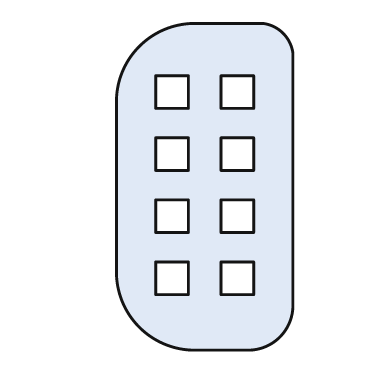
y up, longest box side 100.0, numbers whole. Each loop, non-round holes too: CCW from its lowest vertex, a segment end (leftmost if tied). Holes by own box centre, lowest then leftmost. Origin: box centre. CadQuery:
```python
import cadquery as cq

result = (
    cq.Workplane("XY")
    .moveTo(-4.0, -50.0)
    .lineTo(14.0, -50.0)
    .threePointArc((23.0, -46.0), (27.0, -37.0))
    .lineTo(27.0, 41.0)
    .threePointArc((24.0, 47.0), (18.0, 50.0))
    .lineTo(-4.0, 50.0)
    .threePointArc((-20.0, 43.0), (-27.0, 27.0))
    .lineTo(-27.0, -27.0)
    .threePointArc((-20.0, -43.0), (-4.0, -50.0))
    .close()
    .moveTo(-15.0, -33.0)
    .lineTo(-5.0, -33.0)
    .lineTo(-5.0, -23.0)
    .lineTo(-15.0, -23.0)
    .close()
    .moveTo(5.0, -33.0)
    .lineTo(15.0, -33.0)
    .lineTo(15.0, -23.0)
    .lineTo(5.0, -23.0)
    .close()
    .moveTo(-15.0, -14.0)
    .lineTo(-5.0, -14.0)
    .lineTo(-5.0, -4.0)
    .lineTo(-15.0, -4.0)
    .close()
    .moveTo(5.0, -14.0)
    .lineTo(15.0, -14.0)
    .lineTo(15.0, -4.0)
    .lineTo(5.0, -4.0)
    .close()
    .moveTo(-15.0, 5.0)
    .lineTo(-5.0, 5.0)
    .lineTo(-5.0, 15.0)
    .lineTo(-15.0, 15.0)
    .close()
    .moveTo(5.0, 5.0)
    .lineTo(15.0, 5.0)
    .lineTo(15.0, 15.0)
    .lineTo(5.0, 15.0)
    .close()
    .moveTo(-15.0, 24.0)
    .lineTo(-5.0, 24.0)
    .lineTo(-5.0, 34.0)
    .lineTo(-15.0, 34.0)
    .close()
    .moveTo(5.0, 24.0)
    .lineTo(15.0, 24.0)
    .lineTo(15.0, 34.0)
    .lineTo(5.0, 34.0)
    .close()
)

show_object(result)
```